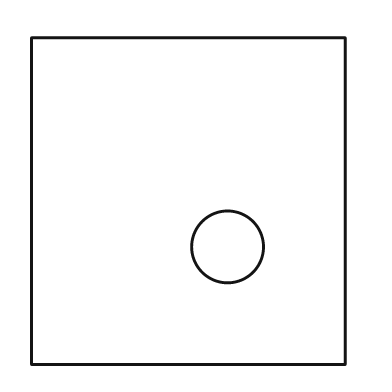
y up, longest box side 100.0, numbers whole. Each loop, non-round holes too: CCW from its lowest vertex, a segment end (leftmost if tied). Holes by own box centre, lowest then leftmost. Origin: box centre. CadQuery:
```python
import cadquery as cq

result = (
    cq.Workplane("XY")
    .moveTo(-48.0, -50.0)
    .lineTo(48.0, -50.0)
    .lineTo(48.0, 50.0)
    .lineTo(-48.0, 50.0)
    .close()
    .moveTo(12.0, -14.0)
    .circle(11.0)
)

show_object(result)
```